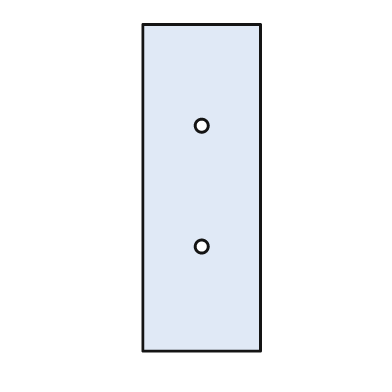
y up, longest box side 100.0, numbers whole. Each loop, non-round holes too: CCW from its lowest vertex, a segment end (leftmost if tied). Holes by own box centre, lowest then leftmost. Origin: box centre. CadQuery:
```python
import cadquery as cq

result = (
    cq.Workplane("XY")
    .moveTo(-18.0, -50.0)
    .lineTo(18.0, -50.0)
    .lineTo(18.0, 50.0)
    .lineTo(-18.0, 50.0)
    .close()
    .moveTo(0.0, -18.0)
    .circle(2.0)
    .moveTo(0.0, 19.0)
    .circle(2.0)
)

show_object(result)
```